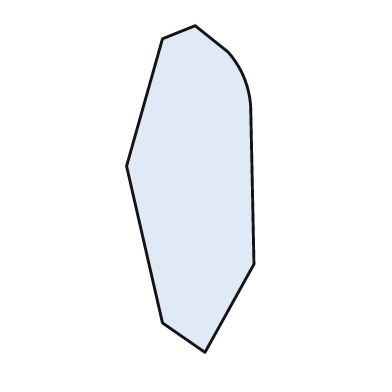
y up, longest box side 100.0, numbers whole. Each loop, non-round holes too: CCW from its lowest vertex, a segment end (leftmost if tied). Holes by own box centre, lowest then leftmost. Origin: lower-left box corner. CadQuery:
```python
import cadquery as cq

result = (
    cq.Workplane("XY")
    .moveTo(24.0, 0.0)
    .lineTo(39.0, 27.0)
    .lineTo(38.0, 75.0)
    .threePointArc((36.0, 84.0), (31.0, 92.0))
    .lineTo(21.0, 100.0)
    .lineTo(11.0, 96.0)
    .lineTo(0.0, 57.0)
    .lineTo(11.0, 9.0)
    .close()
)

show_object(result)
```